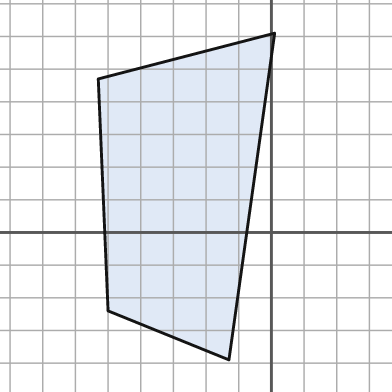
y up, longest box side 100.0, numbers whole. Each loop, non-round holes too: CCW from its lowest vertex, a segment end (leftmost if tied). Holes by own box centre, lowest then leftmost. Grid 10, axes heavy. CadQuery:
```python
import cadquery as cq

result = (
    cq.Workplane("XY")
    .moveTo(-13.0, -39.0)
    .lineTo(1.0, 61.0)
    .lineTo(-53.0, 47.0)
    .lineTo(-50.0, -24.0)
    .close()
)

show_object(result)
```